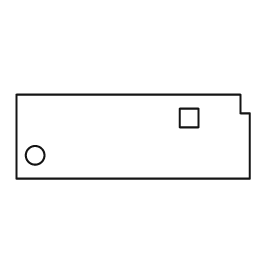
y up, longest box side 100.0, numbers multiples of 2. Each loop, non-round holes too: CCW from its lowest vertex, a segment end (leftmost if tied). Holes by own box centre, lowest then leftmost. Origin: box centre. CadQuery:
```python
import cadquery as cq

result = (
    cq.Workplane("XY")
    .moveTo(-50.0, -18.0)
    .lineTo(50.0, -18.0)
    .lineTo(50.0, 10.0)
    .lineTo(46.0, 10.0)
    .lineTo(46.0, 18.0)
    .lineTo(-50.0, 18.0)
    .close()
    .moveTo(-42.0, -8.0)
    .circle(4.0)
    .moveTo(20.0, 4.0)
    .lineTo(28.0, 4.0)
    .lineTo(28.0, 12.0)
    .lineTo(20.0, 12.0)
    .close()
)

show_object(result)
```